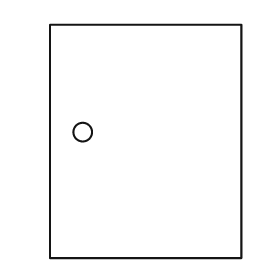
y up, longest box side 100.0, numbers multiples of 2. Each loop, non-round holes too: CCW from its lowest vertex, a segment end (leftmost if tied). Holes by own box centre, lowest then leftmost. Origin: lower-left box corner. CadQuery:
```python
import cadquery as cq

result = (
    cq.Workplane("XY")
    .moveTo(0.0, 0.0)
    .lineTo(82.0, 0.0)
    .lineTo(82.0, 100.0)
    .lineTo(0.0, 100.0)
    .close()
    .moveTo(14.0, 54.0)
    .circle(4.0)
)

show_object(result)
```